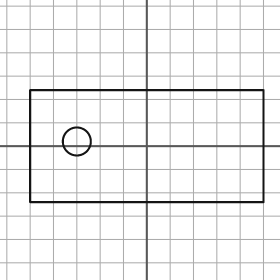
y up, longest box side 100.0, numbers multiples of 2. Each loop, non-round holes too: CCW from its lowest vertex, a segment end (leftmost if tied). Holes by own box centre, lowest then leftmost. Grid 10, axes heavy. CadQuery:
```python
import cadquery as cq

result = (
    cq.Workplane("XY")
    .moveTo(-50.0, -24.0)
    .lineTo(50.0, -24.0)
    .lineTo(50.0, 24.0)
    .lineTo(-50.0, 24.0)
    .close()
    .moveTo(-30.0, 2.0)
    .circle(6.0)
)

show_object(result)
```